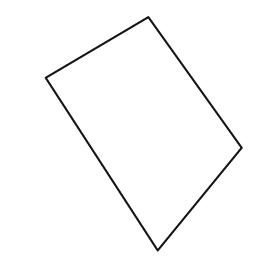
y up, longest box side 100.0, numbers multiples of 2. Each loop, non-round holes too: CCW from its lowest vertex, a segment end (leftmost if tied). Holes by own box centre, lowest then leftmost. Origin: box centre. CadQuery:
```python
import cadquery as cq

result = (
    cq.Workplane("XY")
    .moveTo(6.0, -50.0)
    .lineTo(42.0, -6.0)
    .lineTo(2.0, 50.0)
    .lineTo(-42.0, 24.0)
    .close()
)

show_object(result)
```